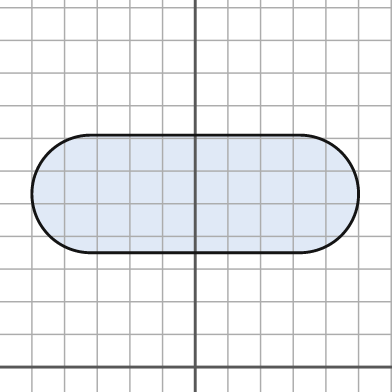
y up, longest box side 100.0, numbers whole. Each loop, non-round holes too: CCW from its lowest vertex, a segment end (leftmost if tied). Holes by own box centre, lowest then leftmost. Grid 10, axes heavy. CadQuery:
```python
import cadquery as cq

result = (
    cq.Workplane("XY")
    .moveTo(-32.0, 35.0)
    .lineTo(32.0, 35.0)
    .threePointArc((50.0, 53.0), (32.0, 71.0))
    .lineTo(-32.0, 71.0)
    .threePointArc((-50.0, 53.0), (-32.0, 35.0))
    .close()
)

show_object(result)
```